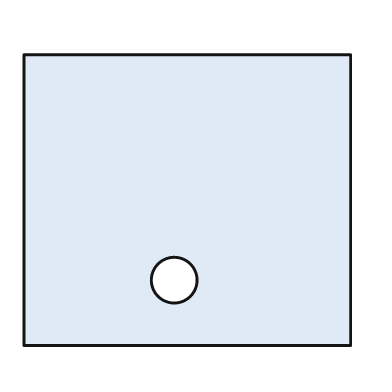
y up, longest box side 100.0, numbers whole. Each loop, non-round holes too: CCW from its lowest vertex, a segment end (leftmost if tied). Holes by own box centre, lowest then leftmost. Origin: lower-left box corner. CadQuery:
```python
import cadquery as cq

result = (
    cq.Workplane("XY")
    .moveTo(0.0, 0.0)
    .lineTo(100.0, 0.0)
    .lineTo(100.0, 89.0)
    .lineTo(0.0, 89.0)
    .close()
    .moveTo(46.0, 20.0)
    .circle(7.0)
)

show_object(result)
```